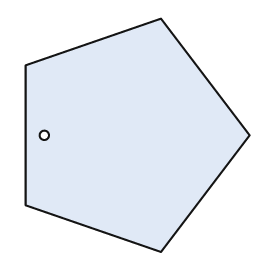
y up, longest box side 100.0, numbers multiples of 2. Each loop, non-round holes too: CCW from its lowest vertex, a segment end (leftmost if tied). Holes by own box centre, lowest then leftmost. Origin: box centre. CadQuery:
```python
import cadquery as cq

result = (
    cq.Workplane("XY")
    .moveTo(10.0, -50.0)
    .lineTo(48.0, 0.0)
    .lineTo(10.0, 50.0)
    .lineTo(-48.0, 30.0)
    .lineTo(-48.0, -30.0)
    .close()
    .moveTo(-40.0, 0.0)
    .circle(2.0)
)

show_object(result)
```